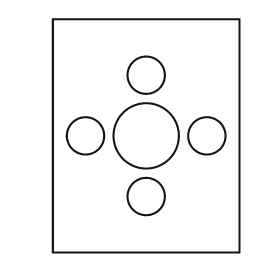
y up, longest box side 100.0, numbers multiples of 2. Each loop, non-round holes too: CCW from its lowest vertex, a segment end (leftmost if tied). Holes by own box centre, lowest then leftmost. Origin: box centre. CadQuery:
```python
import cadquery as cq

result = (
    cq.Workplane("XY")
    .moveTo(-40.0, -50.0)
    .lineTo(40.0, -50.0)
    .lineTo(40.0, 50.0)
    .lineTo(-40.0, 50.0)
    .close()
    .moveTo(0.0, -26.0)
    .circle(8.0)
    .moveTo(-26.0, 0.0)
    .circle(8.0)
    .moveTo(0.0, 0.0)
    .circle(14.0)
    .moveTo(26.0, 0.0)
    .circle(8.0)
    .moveTo(0.0, 26.0)
    .circle(8.0)
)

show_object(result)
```